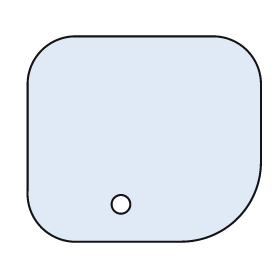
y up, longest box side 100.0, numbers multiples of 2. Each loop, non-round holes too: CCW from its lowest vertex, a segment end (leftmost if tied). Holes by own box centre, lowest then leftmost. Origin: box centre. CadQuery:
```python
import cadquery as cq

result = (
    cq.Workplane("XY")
    .moveTo(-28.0, -44.0)
    .lineTo(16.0, -44.0)
    .threePointArc((40.0, -34.0), (50.0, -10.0))
    .lineTo(50.0, 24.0)
    .threePointArc((44.0, 38.0), (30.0, 44.0))
    .lineTo(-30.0, 44.0)
    .threePointArc((-44.0, 38.0), (-50.0, 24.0))
    .lineTo(-50.0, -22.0)
    .threePointArc((-44.0, -38.0), (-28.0, -44.0))
    .close()
    .moveTo(-10.0, -28.0)
    .circle(4.0)
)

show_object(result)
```